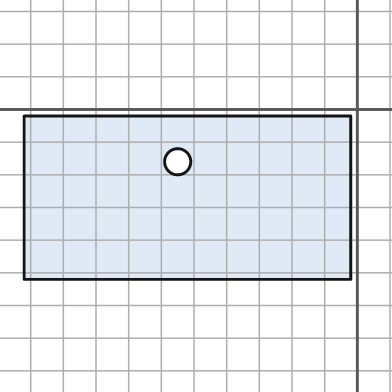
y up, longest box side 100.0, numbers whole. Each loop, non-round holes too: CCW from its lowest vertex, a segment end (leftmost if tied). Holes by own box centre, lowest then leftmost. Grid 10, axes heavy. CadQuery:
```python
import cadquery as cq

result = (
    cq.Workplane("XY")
    .moveTo(-102.0, -52.0)
    .lineTo(-2.0, -52.0)
    .lineTo(-2.0, -2.0)
    .lineTo(-102.0, -2.0)
    .close()
    .moveTo(-55.0, -16.0)
    .circle(4.0)
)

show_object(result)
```